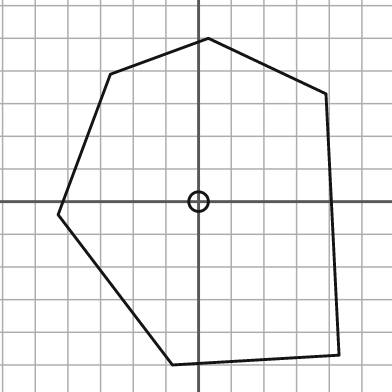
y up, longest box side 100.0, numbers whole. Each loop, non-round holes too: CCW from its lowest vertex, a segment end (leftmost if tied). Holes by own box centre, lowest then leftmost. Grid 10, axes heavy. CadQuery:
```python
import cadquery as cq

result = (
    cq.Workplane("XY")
    .moveTo(-8.0, -50.0)
    .lineTo(43.0, -47.0)
    .lineTo(39.0, 33.0)
    .lineTo(3.0, 50.0)
    .lineTo(-27.0, 39.0)
    .lineTo(-43.0, -4.0)
    .close()
    .moveTo(0.0, 0.0)
    .circle(3.0)
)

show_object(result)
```